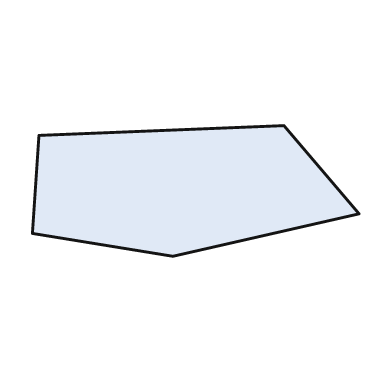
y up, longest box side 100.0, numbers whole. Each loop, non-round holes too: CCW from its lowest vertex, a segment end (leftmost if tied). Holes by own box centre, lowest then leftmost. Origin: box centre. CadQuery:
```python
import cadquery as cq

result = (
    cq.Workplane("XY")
    .moveTo(-7.0, -20.0)
    .lineTo(50.0, -7.0)
    .lineTo(27.0, 20.0)
    .lineTo(-48.0, 17.0)
    .lineTo(-50.0, -13.0)
    .close()
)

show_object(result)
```